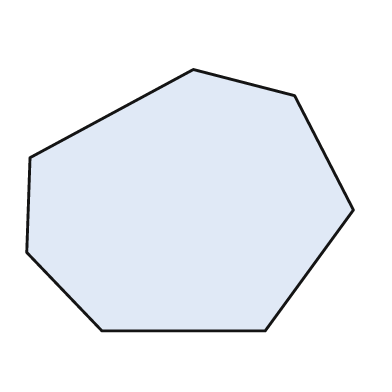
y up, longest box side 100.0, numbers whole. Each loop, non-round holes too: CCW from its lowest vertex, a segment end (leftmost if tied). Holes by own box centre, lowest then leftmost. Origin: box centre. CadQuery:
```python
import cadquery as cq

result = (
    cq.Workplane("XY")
    .moveTo(-27.0, -40.0)
    .lineTo(23.0, -40.0)
    .lineTo(50.0, -3.0)
    .lineTo(32.0, 32.0)
    .lineTo(1.0, 40.0)
    .lineTo(-49.0, 13.0)
    .lineTo(-50.0, -16.0)
    .close()
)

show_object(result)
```